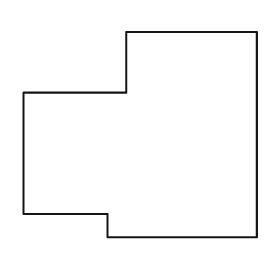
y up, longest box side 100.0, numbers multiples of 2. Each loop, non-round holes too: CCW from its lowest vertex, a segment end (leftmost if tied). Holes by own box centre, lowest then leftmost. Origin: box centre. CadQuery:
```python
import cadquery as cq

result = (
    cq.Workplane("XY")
    .moveTo(-14.0, -44.0)
    .lineTo(50.0, -44.0)
    .lineTo(50.0, 44.0)
    .lineTo(-6.0, 44.0)
    .lineTo(-6.0, 18.0)
    .lineTo(-50.0, 18.0)
    .lineTo(-50.0, -34.0)
    .lineTo(-14.0, -34.0)
    .close()
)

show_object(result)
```